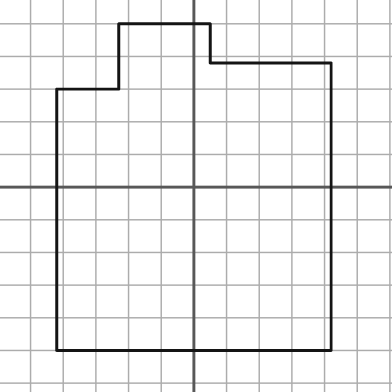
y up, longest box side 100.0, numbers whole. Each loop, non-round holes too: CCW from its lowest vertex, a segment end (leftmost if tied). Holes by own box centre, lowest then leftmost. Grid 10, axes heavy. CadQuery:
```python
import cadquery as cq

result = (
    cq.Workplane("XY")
    .moveTo(-42.0, -50.0)
    .lineTo(42.0, -50.0)
    .lineTo(42.0, 38.0)
    .lineTo(5.0, 38.0)
    .lineTo(5.0, 50.0)
    .lineTo(-23.0, 50.0)
    .lineTo(-23.0, 30.0)
    .lineTo(-42.0, 30.0)
    .close()
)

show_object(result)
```